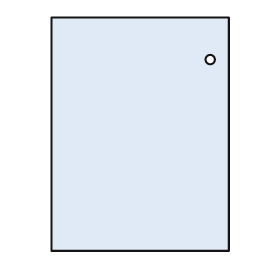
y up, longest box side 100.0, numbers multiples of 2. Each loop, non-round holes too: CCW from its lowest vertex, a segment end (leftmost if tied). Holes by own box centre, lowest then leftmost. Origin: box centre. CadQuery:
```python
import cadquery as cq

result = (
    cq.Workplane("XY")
    .moveTo(-38.0, -50.0)
    .lineTo(38.0, -50.0)
    .lineTo(38.0, 50.0)
    .lineTo(-38.0, 50.0)
    .close()
    .moveTo(30.0, 32.0)
    .circle(2.0)
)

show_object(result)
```